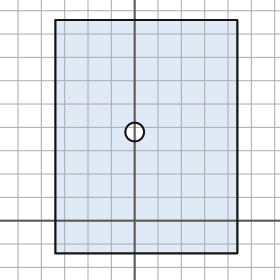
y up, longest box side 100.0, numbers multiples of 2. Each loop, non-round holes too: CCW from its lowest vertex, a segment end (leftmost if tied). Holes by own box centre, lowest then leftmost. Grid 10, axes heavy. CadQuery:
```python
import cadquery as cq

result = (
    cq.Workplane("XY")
    .moveTo(-34.0, -14.0)
    .lineTo(44.0, -14.0)
    .lineTo(44.0, 86.0)
    .lineTo(-34.0, 86.0)
    .close()
    .moveTo(0.0, 38.0)
    .circle(4.0)
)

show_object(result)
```